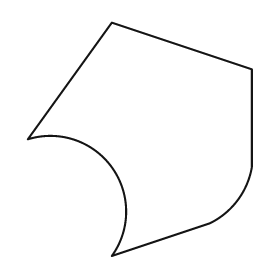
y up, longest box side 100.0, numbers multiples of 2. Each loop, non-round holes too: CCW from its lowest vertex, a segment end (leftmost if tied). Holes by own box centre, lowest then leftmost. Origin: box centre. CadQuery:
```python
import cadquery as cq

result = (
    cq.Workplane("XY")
    .moveTo(-12.0, -50.0)
    .lineTo(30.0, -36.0)
    .threePointArc((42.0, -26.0), (48.0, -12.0))
    .lineTo(48.0, 30.0)
    .lineTo(-12.0, 50.0)
    .lineTo(-48.0, 0.0)
    .threePointArc((-12.0, -12.0), (-12.0, -50.0))
    .close()
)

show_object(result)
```